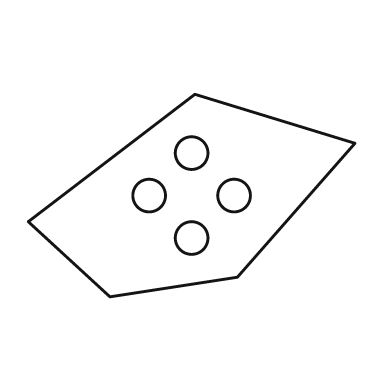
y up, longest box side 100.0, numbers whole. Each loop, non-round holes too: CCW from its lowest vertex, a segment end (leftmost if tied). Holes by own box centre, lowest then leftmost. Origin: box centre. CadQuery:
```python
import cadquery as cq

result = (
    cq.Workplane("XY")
    .moveTo(-25.0, -31.0)
    .lineTo(14.0, -25.0)
    .lineTo(50.0, 16.0)
    .lineTo(1.0, 31.0)
    .lineTo(-50.0, -8.0)
    .close()
    .moveTo(0.0, -13.0)
    .circle(5.0)
    .moveTo(-13.0, 0.0)
    .circle(5.0)
    .moveTo(13.0, 0.0)
    .circle(5.0)
    .moveTo(0.0, 13.0)
    .circle(5.0)
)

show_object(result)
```